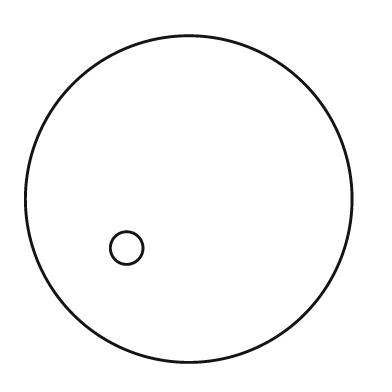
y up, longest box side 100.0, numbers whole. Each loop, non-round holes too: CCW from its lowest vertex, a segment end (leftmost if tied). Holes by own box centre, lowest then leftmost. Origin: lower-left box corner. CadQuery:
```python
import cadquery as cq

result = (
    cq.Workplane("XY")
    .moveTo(50.0, 50.0)
    .circle(50.0)
    .moveTo(31.0, 35.0)
    .circle(5.0)
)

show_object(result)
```